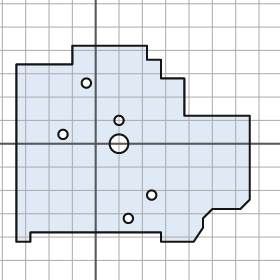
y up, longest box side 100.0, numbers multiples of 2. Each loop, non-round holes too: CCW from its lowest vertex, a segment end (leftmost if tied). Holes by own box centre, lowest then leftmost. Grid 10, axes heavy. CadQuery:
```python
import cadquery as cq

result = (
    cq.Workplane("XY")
    .moveTo(-34.0, -42.0)
    .lineTo(-28.0, -42.0)
    .lineTo(-28.0, -38.0)
    .lineTo(28.0, -38.0)
    .lineTo(28.0, -42.0)
    .lineTo(42.0, -42.0)
    .lineTo(46.0, -36.0)
    .lineTo(46.0, -32.0)
    .lineTo(50.0, -28.0)
    .lineTo(62.0, -28.0)
    .lineTo(66.0, -24.0)
    .lineTo(66.0, 12.0)
    .lineTo(38.0, 12.0)
    .lineTo(38.0, 28.0)
    .lineTo(28.0, 28.0)
    .lineTo(28.0, 36.0)
    .lineTo(22.0, 36.0)
    .lineTo(22.0, 42.0)
    .lineTo(-10.0, 42.0)
    .lineTo(-10.0, 34.0)
    .lineTo(-34.0, 34.0)
    .close()
    .moveTo(14.0, -32.0)
    .circle(2.0)
    .moveTo(24.0, -22.0)
    .circle(2.0)
    .moveTo(10.0, 0.0)
    .circle(4.0)
    .moveTo(-14.0, 4.0)
    .circle(2.0)
    .moveTo(10.0, 10.0)
    .circle(2.0)
    .moveTo(-4.0, 26.0)
    .circle(2.0)
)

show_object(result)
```